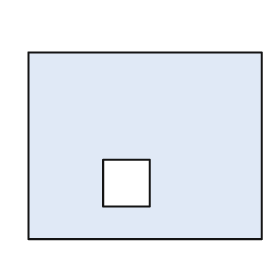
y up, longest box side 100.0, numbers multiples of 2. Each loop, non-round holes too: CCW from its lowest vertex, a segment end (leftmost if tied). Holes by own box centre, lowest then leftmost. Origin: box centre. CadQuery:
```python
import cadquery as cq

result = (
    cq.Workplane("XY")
    .moveTo(-50.0, -40.0)
    .lineTo(50.0, -40.0)
    .lineTo(50.0, 40.0)
    .lineTo(-50.0, 40.0)
    .close()
    .moveTo(-18.0, -26.0)
    .lineTo(2.0, -26.0)
    .lineTo(2.0, -6.0)
    .lineTo(-18.0, -6.0)
    .close()
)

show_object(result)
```